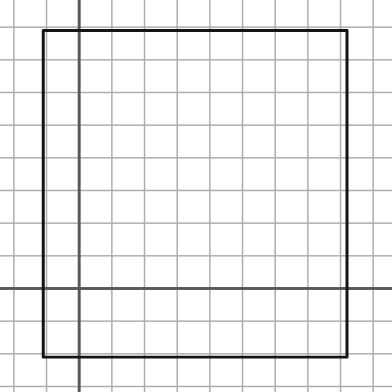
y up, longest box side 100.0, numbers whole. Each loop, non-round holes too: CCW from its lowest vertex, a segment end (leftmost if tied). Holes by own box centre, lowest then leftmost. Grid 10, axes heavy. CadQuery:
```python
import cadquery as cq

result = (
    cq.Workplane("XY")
    .moveTo(-11.0, -21.0)
    .lineTo(82.0, -21.0)
    .lineTo(82.0, 79.0)
    .lineTo(-11.0, 79.0)
    .close()
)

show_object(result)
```